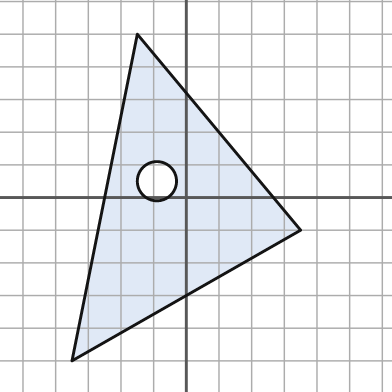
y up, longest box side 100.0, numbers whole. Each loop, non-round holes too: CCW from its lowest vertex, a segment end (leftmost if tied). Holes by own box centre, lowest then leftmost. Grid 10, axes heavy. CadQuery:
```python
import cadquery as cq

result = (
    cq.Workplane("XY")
    .moveTo(-35.0, -50.0)
    .lineTo(35.0, -10.0)
    .lineTo(-15.0, 50.0)
    .close()
    .moveTo(-9.0, 5.0)
    .circle(6.0)
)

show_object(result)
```